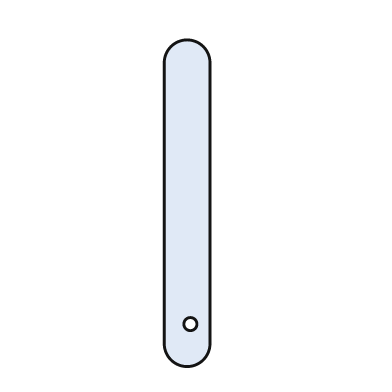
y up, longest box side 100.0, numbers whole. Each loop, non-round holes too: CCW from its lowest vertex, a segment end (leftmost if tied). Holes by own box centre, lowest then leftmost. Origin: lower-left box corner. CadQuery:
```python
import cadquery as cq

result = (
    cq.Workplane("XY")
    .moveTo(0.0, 7.0)
    .threePointArc((7.0, 0.0), (14.0, 7.0))
    .lineTo(14.0, 93.0)
    .threePointArc((7.0, 100.0), (0.0, 93.0))
    .close()
    .moveTo(8.0, 13.0)
    .circle(2.0)
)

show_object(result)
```